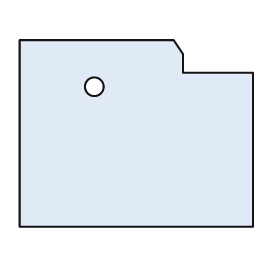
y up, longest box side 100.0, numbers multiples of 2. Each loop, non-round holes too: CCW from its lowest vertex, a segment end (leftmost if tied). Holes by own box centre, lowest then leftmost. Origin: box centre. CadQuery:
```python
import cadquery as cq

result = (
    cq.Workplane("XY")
    .moveTo(-50.0, -40.0)
    .lineTo(50.0, -40.0)
    .lineTo(50.0, 26.0)
    .lineTo(20.0, 26.0)
    .lineTo(20.0, 34.0)
    .lineTo(16.0, 40.0)
    .lineTo(-50.0, 40.0)
    .close()
    .moveTo(-18.0, 20.0)
    .circle(4.0)
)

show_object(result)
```